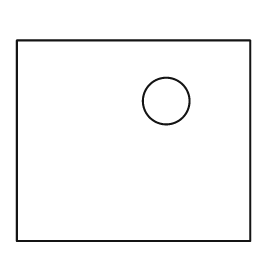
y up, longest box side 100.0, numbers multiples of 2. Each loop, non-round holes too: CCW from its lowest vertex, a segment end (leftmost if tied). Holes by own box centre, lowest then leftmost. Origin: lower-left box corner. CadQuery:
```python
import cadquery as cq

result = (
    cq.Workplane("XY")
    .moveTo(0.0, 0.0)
    .lineTo(100.0, 0.0)
    .lineTo(100.0, 86.0)
    .lineTo(0.0, 86.0)
    .close()
    .moveTo(64.0, 60.0)
    .circle(10.0)
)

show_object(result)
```